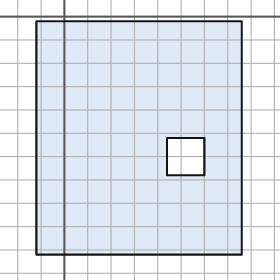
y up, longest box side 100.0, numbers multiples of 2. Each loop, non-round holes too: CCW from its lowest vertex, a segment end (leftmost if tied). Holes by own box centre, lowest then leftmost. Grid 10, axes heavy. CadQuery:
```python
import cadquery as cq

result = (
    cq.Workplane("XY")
    .moveTo(-12.0, -102.0)
    .lineTo(76.0, -102.0)
    .lineTo(76.0, -2.0)
    .lineTo(-12.0, -2.0)
    .close()
    .moveTo(44.0, -68.0)
    .lineTo(60.0, -68.0)
    .lineTo(60.0, -52.0)
    .lineTo(44.0, -52.0)
    .close()
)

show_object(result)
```